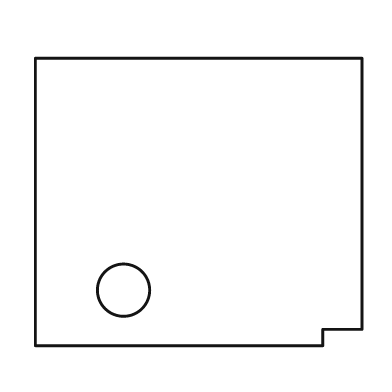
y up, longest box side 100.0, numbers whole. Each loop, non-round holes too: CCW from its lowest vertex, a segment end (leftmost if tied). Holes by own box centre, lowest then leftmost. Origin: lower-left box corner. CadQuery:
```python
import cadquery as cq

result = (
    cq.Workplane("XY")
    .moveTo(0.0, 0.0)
    .lineTo(88.0, 0.0)
    .lineTo(88.0, 5.0)
    .lineTo(100.0, 5.0)
    .lineTo(100.0, 88.0)
    .lineTo(0.0, 88.0)
    .close()
    .moveTo(27.0, 17.0)
    .circle(8.0)
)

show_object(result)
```